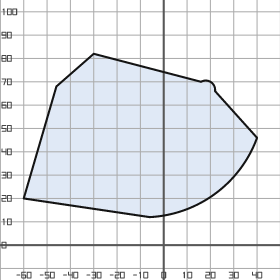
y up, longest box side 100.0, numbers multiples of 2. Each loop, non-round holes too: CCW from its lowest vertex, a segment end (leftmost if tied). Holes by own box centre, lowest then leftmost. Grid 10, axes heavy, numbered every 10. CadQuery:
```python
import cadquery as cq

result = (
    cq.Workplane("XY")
    .moveTo(-6.0, 12.0)
    .threePointArc((22.0, 22.0), (40.0, 46.0))
    .lineTo(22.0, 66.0)
    .threePointArc((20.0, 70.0), (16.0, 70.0))
    .lineTo(-30.0, 82.0)
    .lineTo(-46.0, 68.0)
    .lineTo(-60.0, 20.0)
    .close()
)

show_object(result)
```